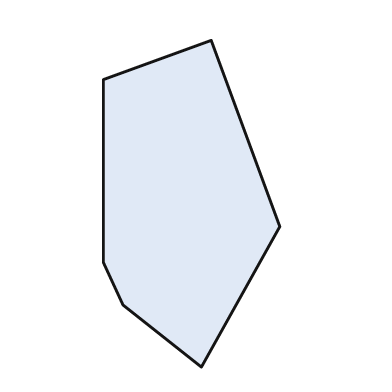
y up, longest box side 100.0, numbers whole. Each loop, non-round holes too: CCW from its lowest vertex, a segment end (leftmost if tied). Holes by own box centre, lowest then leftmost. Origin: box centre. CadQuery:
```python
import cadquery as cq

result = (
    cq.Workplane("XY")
    .moveTo(3.0, -50.0)
    .lineTo(27.0, -7.0)
    .lineTo(6.0, 50.0)
    .lineTo(-27.0, 38.0)
    .lineTo(-27.0, -18.0)
    .lineTo(-21.0, -31.0)
    .close()
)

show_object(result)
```